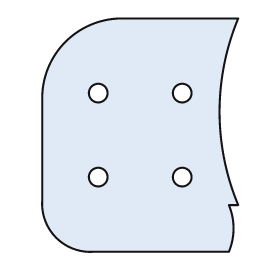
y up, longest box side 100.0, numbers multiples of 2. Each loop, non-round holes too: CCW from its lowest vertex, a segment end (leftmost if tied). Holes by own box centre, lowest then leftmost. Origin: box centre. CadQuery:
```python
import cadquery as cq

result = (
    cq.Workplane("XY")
    .moveTo(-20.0, -50.0)
    .lineTo(38.0, -50.0)
    .threePointArc((40.0, -40.0), (38.0, -30.0))
    .lineTo(42.0, -30.0)
    .threePointArc((34.0, 10.0), (42.0, 50.0))
    .lineTo(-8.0, 50.0)
    .threePointArc((-32.0, 40.0), (-42.0, 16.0))
    .lineTo(-42.0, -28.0)
    .threePointArc((-36.0, -44.0), (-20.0, -50.0))
    .close()
    .moveTo(-18.0, -18.0)
    .circle(4.0)
    .moveTo(18.0, -18.0)
    .circle(4.0)
    .moveTo(-18.0, 18.0)
    .circle(4.0)
    .moveTo(18.0, 18.0)
    .circle(4.0)
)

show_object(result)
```